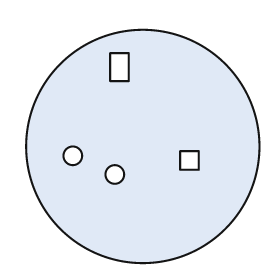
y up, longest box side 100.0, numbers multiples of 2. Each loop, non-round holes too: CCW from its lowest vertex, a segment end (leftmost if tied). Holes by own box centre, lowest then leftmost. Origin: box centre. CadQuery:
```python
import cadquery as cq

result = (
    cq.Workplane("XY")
    .moveTo(0.0, 0.0)
    .circle(50.0)
    .moveTo(-12.0, -12.0)
    .circle(4.0)
    .moveTo(16.0, -10.0)
    .lineTo(24.0, -10.0)
    .lineTo(24.0, -2.0)
    .lineTo(16.0, -2.0)
    .close()
    .moveTo(-30.0, -4.0)
    .circle(4.0)
    .moveTo(-14.0, 28.0)
    .lineTo(-6.0, 28.0)
    .lineTo(-6.0, 40.0)
    .lineTo(-14.0, 40.0)
    .close()
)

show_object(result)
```